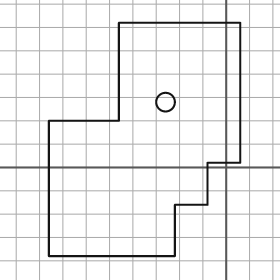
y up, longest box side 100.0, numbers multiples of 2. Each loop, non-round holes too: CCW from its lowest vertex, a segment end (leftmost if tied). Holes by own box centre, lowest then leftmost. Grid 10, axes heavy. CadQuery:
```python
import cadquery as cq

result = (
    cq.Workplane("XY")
    .moveTo(-76.0, -38.0)
    .lineTo(-22.0, -38.0)
    .lineTo(-22.0, -16.0)
    .lineTo(-8.0, -16.0)
    .lineTo(-8.0, 2.0)
    .lineTo(6.0, 2.0)
    .lineTo(6.0, 62.0)
    .lineTo(-46.0, 62.0)
    .lineTo(-46.0, 20.0)
    .lineTo(-76.0, 20.0)
    .close()
    .moveTo(-26.0, 28.0)
    .circle(4.0)
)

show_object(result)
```